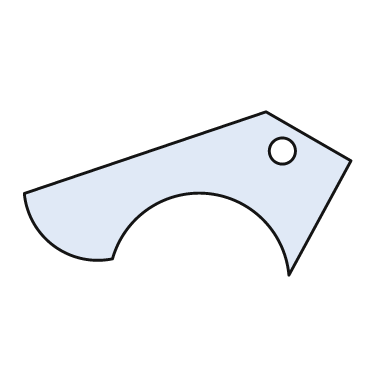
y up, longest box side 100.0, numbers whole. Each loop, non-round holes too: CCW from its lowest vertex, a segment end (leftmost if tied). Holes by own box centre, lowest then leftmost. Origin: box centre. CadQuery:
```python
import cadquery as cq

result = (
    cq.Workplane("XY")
    .moveTo(31.0, -25.0)
    .lineTo(50.0, 10.0)
    .lineTo(24.0, 25.0)
    .lineTo(-50.0, 0.0)
    .threePointArc((-41.0, -16.0), (-23.0, -20.0))
    .threePointArc((6.0, 0.0), (31.0, -25.0))
    .close()
    .moveTo(29.0, 13.0)
    .circle(4.0)
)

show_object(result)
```